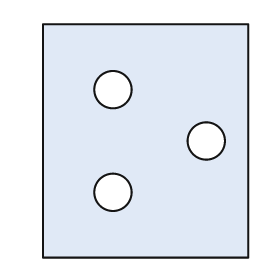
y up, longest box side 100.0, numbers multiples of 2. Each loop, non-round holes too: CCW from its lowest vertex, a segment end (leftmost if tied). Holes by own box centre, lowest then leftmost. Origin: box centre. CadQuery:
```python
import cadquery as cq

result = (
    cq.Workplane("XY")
    .moveTo(-44.0, -50.0)
    .lineTo(44.0, -50.0)
    .lineTo(44.0, 50.0)
    .lineTo(-44.0, 50.0)
    .close()
    .moveTo(-14.0, -22.0)
    .circle(8.0)
    .moveTo(26.0, 0.0)
    .circle(8.0)
    .moveTo(-14.0, 22.0)
    .circle(8.0)
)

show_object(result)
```